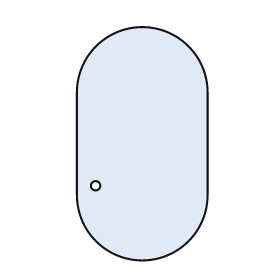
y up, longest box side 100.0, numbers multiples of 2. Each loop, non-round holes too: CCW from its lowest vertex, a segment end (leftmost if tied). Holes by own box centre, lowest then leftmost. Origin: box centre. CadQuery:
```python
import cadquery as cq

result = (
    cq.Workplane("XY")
    .moveTo(-28.0, -22.0)
    .threePointArc((0.0, -50.0), (28.0, -22.0))
    .lineTo(28.0, 22.0)
    .threePointArc((0.0, 50.0), (-28.0, 22.0))
    .close()
    .moveTo(-20.0, -18.0)
    .circle(2.0)
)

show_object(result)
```